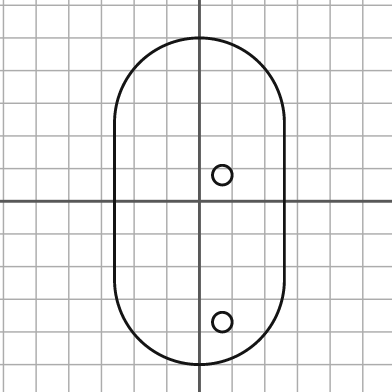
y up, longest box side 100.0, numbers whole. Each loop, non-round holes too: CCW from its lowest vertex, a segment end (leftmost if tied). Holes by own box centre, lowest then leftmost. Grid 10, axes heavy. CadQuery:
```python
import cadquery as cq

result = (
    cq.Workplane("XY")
    .moveTo(-26.0, -24.0)
    .threePointArc((0.0, -50.0), (26.0, -24.0))
    .lineTo(26.0, 24.0)
    .threePointArc((0.0, 50.0), (-26.0, 24.0))
    .close()
    .moveTo(7.0, -37.0)
    .circle(3.0)
    .moveTo(7.0, 8.0)
    .circle(3.0)
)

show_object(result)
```